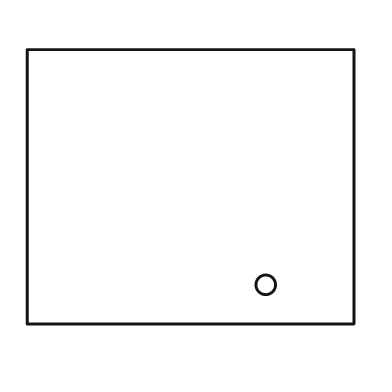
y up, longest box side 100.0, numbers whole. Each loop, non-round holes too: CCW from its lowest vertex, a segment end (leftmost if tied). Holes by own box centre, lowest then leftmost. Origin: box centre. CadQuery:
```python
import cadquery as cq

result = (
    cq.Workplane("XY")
    .moveTo(-50.0, -42.0)
    .lineTo(50.0, -42.0)
    .lineTo(50.0, 42.0)
    .lineTo(-50.0, 42.0)
    .close()
    .moveTo(23.0, -30.0)
    .circle(3.0)
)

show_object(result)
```